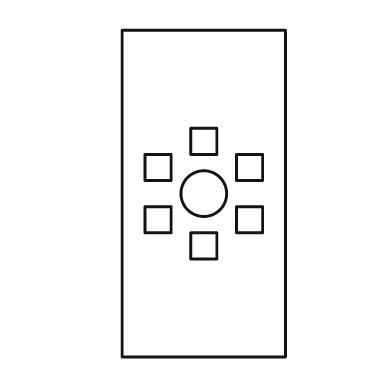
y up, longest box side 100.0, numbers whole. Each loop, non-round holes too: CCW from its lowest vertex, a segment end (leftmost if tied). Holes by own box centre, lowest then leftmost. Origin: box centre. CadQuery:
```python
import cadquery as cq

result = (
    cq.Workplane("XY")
    .moveTo(-25.0, -50.0)
    .lineTo(25.0, -50.0)
    .lineTo(25.0, 50.0)
    .lineTo(-25.0, 50.0)
    .close()
    .moveTo(-4.0, -20.0)
    .lineTo(4.0, -20.0)
    .lineTo(4.0, -12.0)
    .lineTo(-4.0, -12.0)
    .close()
    .moveTo(-18.0, -12.0)
    .lineTo(-10.0, -12.0)
    .lineTo(-10.0, -4.0)
    .lineTo(-18.0, -4.0)
    .close()
    .moveTo(10.0, -12.0)
    .lineTo(18.0, -12.0)
    .lineTo(18.0, -4.0)
    .lineTo(10.0, -4.0)
    .close()
    .moveTo(0.0, 0.0)
    .circle(7.0)
    .moveTo(-18.0, 4.0)
    .lineTo(-10.0, 4.0)
    .lineTo(-10.0, 12.0)
    .lineTo(-18.0, 12.0)
    .close()
    .moveTo(10.0, 4.0)
    .lineTo(18.0, 4.0)
    .lineTo(18.0, 12.0)
    .lineTo(10.0, 12.0)
    .close()
    .moveTo(-4.0, 12.0)
    .lineTo(4.0, 12.0)
    .lineTo(4.0, 20.0)
    .lineTo(-4.0, 20.0)
    .close()
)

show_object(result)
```